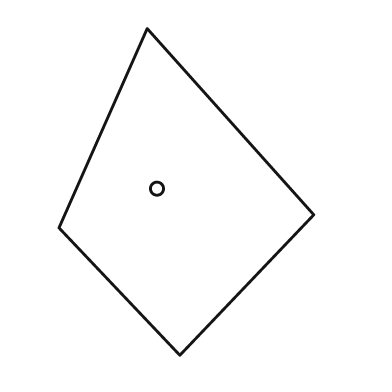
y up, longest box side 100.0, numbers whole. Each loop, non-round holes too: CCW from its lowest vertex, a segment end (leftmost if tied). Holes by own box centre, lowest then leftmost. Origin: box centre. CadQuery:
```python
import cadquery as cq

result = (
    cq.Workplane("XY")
    .moveTo(-2.0, -50.0)
    .lineTo(39.0, -7.0)
    .lineTo(-12.0, 50.0)
    .lineTo(-39.0, -11.0)
    .close()
    .moveTo(-9.0, 1.0)
    .circle(2.0)
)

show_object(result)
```